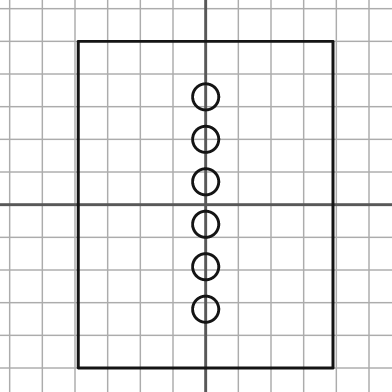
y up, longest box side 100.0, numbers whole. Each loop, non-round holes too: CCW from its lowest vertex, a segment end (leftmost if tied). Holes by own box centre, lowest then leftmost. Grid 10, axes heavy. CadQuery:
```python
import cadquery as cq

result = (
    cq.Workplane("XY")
    .moveTo(-39.0, -50.0)
    .lineTo(39.0, -50.0)
    .lineTo(39.0, 50.0)
    .lineTo(-39.0, 50.0)
    .close()
    .moveTo(0.0, -32.0)
    .circle(4.0)
    .moveTo(0.0, -19.0)
    .circle(4.0)
    .moveTo(0.0, -6.0)
    .circle(4.0)
    .moveTo(0.0, 7.0)
    .circle(4.0)
    .moveTo(0.0, 20.0)
    .circle(4.0)
    .moveTo(0.0, 33.0)
    .circle(4.0)
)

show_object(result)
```